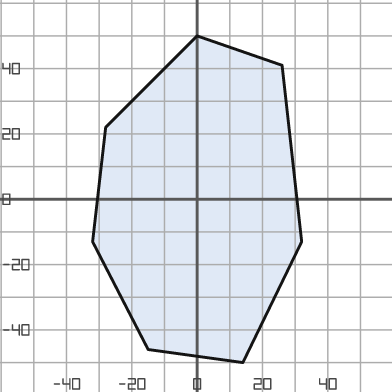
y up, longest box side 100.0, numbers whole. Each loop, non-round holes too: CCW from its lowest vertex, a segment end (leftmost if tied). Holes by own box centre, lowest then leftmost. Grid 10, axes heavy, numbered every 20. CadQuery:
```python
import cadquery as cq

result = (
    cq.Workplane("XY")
    .moveTo(14.0, -50.0)
    .lineTo(32.0, -13.0)
    .lineTo(26.0, 41.0)
    .lineTo(0.0, 50.0)
    .lineTo(-28.0, 22.0)
    .lineTo(-32.0, -13.0)
    .lineTo(-15.0, -46.0)
    .close()
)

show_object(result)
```